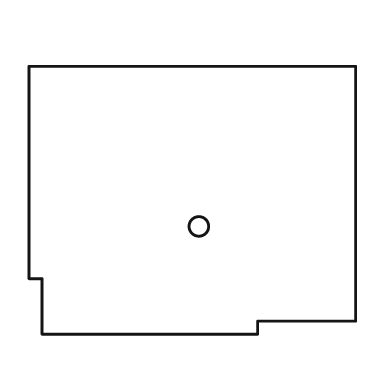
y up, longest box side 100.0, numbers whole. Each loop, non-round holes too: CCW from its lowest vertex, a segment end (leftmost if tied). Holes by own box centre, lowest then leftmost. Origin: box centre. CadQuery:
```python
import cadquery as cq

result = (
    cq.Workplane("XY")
    .moveTo(-46.0, -41.0)
    .lineTo(20.0, -41.0)
    .lineTo(20.0, -37.0)
    .lineTo(50.0, -37.0)
    .lineTo(50.0, 41.0)
    .lineTo(-50.0, 41.0)
    .lineTo(-50.0, -24.0)
    .lineTo(-46.0, -24.0)
    .close()
    .moveTo(2.0, -8.0)
    .circle(3.0)
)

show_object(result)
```